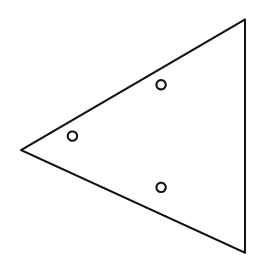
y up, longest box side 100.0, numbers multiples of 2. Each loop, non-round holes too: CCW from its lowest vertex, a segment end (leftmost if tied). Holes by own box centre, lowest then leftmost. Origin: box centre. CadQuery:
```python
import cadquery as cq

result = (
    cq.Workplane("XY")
    .moveTo(48.0, -50.0)
    .lineTo(48.0, 50.0)
    .lineTo(-48.0, -6.0)
    .close()
    .moveTo(12.0, -22.0)
    .circle(2.0)
    .moveTo(-26.0, 0.0)
    .circle(2.0)
    .moveTo(12.0, 22.0)
    .circle(2.0)
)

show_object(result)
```